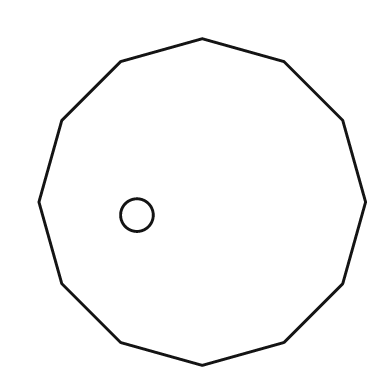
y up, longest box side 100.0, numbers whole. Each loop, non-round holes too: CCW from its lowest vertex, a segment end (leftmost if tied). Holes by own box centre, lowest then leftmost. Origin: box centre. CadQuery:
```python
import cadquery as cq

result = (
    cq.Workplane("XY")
    .moveTo(0.0, -50.0)
    .lineTo(25.0, -43.0)
    .lineTo(43.0, -25.0)
    .lineTo(50.0, 0.0)
    .lineTo(43.0, 25.0)
    .lineTo(25.0, 43.0)
    .lineTo(0.0, 50.0)
    .lineTo(-25.0, 43.0)
    .lineTo(-43.0, 25.0)
    .lineTo(-50.0, 0.0)
    .lineTo(-43.0, -25.0)
    .lineTo(-25.0, -43.0)
    .close()
    .moveTo(-20.0, -4.0)
    .circle(5.0)
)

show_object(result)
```